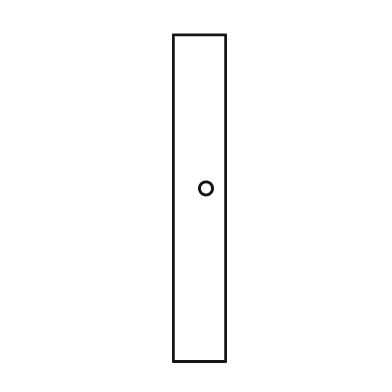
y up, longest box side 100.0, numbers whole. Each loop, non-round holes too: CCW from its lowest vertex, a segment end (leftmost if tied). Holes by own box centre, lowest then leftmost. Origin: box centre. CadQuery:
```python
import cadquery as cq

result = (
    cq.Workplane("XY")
    .moveTo(-8.0, -50.0)
    .lineTo(8.0, -50.0)
    .lineTo(8.0, 50.0)
    .lineTo(-8.0, 50.0)
    .close()
    .moveTo(2.0, 3.0)
    .circle(2.0)
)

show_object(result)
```